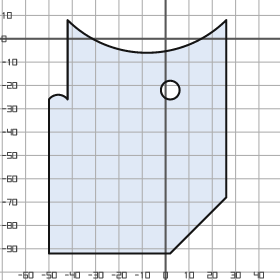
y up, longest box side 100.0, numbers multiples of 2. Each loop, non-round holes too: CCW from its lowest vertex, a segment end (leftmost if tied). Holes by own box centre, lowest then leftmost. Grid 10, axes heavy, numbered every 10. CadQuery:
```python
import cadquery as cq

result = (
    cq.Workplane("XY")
    .moveTo(-50.0, -92.0)
    .lineTo(2.0, -92.0)
    .lineTo(26.0, -68.0)
    .lineTo(26.0, 8.0)
    .threePointArc((-8.0, -6.0), (-42.0, 8.0))
    .lineTo(-42.0, -26.0)
    .threePointArc((-46.0, -24.0), (-50.0, -26.0))
    .close()
    .moveTo(2.0, -22.0)
    .circle(4.0)
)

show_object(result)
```